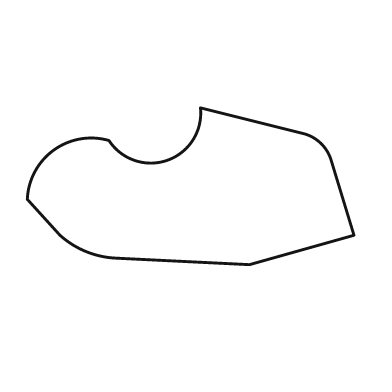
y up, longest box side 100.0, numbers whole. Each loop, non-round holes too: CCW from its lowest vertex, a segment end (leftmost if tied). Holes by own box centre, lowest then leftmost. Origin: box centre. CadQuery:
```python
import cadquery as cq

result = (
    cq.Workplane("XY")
    .moveTo(18.0, -24.0)
    .lineTo(50.0, -15.0)
    .lineTo(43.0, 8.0)
    .threePointArc((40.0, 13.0), (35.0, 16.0))
    .lineTo(3.0, 24.0)
    .threePointArc((-7.0, 8.0), (-25.0, 14.0))
    .threePointArc((-42.0, 11.0), (-50.0, -4.0))
    .lineTo(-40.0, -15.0)
    .threePointArc((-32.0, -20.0), (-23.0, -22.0))
    .close()
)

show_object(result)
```